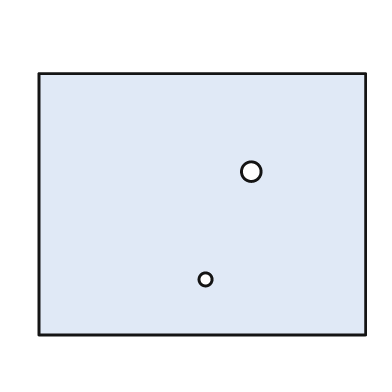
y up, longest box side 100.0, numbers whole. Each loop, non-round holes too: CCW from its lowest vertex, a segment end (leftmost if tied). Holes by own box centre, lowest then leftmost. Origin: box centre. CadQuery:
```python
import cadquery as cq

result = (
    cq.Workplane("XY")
    .moveTo(-50.0, -40.0)
    .lineTo(50.0, -40.0)
    .lineTo(50.0, 40.0)
    .lineTo(-50.0, 40.0)
    .close()
    .moveTo(1.0, -23.0)
    .circle(2.0)
    .moveTo(15.0, 10.0)
    .circle(3.0)
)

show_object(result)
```